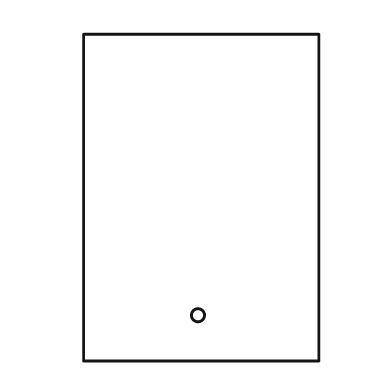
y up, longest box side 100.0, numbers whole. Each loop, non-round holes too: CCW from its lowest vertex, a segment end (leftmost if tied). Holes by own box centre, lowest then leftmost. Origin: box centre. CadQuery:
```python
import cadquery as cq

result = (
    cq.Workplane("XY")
    .moveTo(-36.0, -50.0)
    .lineTo(36.0, -50.0)
    .lineTo(36.0, 50.0)
    .lineTo(-36.0, 50.0)
    .close()
    .moveTo(-1.0, -36.0)
    .circle(2.0)
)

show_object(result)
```